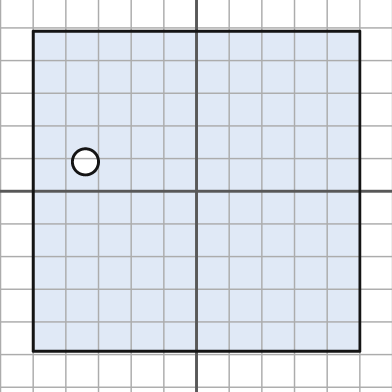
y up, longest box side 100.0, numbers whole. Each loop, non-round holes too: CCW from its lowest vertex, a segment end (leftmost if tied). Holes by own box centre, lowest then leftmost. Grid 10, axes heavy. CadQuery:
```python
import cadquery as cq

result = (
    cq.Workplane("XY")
    .moveTo(-50.0, -49.0)
    .lineTo(50.0, -49.0)
    .lineTo(50.0, 49.0)
    .lineTo(-50.0, 49.0)
    .close()
    .moveTo(-34.0, 9.0)
    .circle(4.0)
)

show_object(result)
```